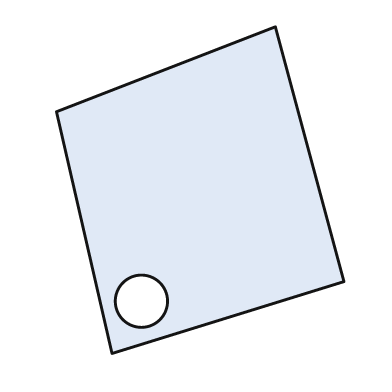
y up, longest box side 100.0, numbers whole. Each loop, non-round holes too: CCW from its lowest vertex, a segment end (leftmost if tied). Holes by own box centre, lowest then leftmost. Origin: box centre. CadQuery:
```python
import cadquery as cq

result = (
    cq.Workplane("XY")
    .moveTo(-27.0, -50.0)
    .lineTo(44.0, -28.0)
    .lineTo(23.0, 50.0)
    .lineTo(-44.0, 24.0)
    .close()
    .moveTo(-18.0, -34.0)
    .circle(8.0)
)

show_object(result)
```